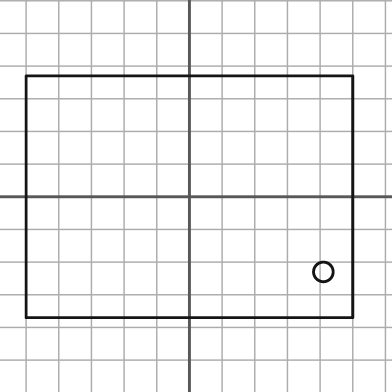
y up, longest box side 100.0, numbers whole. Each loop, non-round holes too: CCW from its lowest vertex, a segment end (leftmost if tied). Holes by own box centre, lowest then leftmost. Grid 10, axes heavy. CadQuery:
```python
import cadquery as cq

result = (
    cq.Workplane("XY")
    .moveTo(-50.0, -37.0)
    .lineTo(50.0, -37.0)
    .lineTo(50.0, 37.0)
    .lineTo(-50.0, 37.0)
    .close()
    .moveTo(41.0, -23.0)
    .circle(3.0)
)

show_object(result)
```